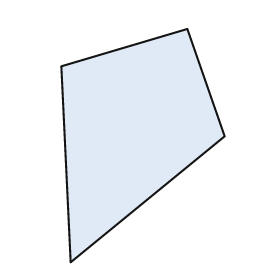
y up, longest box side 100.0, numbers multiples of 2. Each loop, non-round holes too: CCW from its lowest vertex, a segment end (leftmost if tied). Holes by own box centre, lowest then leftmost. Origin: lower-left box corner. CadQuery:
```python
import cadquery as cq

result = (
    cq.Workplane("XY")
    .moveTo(4.0, 0.0)
    .lineTo(70.0, 54.0)
    .lineTo(54.0, 100.0)
    .lineTo(0.0, 84.0)
    .close()
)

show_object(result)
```